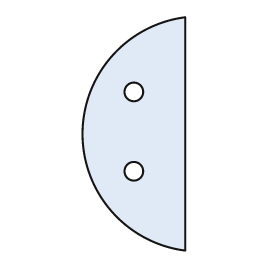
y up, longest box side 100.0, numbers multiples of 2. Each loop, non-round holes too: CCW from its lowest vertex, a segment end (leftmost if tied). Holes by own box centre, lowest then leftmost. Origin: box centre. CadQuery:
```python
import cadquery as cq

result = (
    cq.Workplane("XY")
    .moveTo(22.0, -50.0)
    .lineTo(22.0, 50.0)
    .threePointArc((-22.0, 0.0), (22.0, -50.0))
    .close()
    .moveTo(0.0, -16.0)
    .circle(4.0)
    .moveTo(0.0, 18.0)
    .circle(4.0)
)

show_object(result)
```